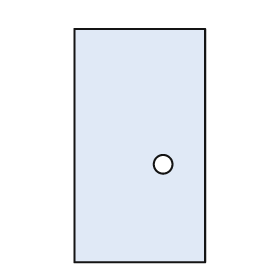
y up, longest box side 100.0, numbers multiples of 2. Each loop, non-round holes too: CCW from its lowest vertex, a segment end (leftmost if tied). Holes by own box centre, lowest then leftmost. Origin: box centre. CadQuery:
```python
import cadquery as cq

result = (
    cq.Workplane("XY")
    .moveTo(-28.0, -50.0)
    .lineTo(28.0, -50.0)
    .lineTo(28.0, 50.0)
    .lineTo(-28.0, 50.0)
    .close()
    .moveTo(10.0, -8.0)
    .circle(4.0)
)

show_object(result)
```